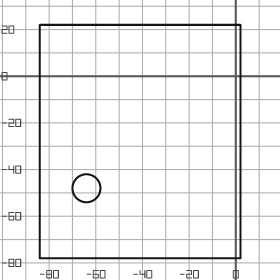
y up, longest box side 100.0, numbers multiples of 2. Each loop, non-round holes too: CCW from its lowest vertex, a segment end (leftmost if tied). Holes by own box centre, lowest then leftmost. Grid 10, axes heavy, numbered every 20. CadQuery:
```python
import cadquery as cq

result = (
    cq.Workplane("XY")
    .moveTo(-84.0, -78.0)
    .lineTo(2.0, -78.0)
    .lineTo(2.0, 22.0)
    .lineTo(-84.0, 22.0)
    .close()
    .moveTo(-64.0, -48.0)
    .circle(6.0)
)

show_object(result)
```